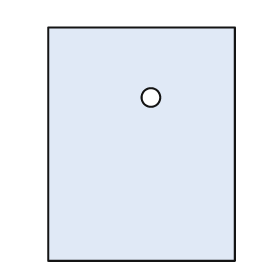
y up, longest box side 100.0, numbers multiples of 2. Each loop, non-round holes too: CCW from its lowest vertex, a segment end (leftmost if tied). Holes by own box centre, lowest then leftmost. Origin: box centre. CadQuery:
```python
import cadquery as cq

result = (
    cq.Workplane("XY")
    .moveTo(-40.0, -50.0)
    .lineTo(40.0, -50.0)
    .lineTo(40.0, 50.0)
    .lineTo(-40.0, 50.0)
    .close()
    .moveTo(4.0, 20.0)
    .circle(4.0)
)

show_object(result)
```